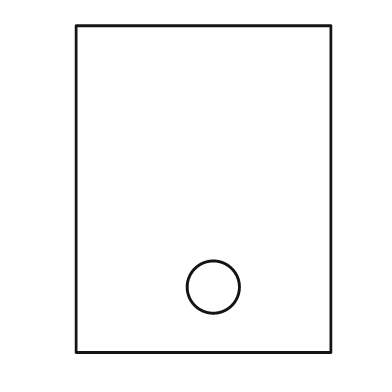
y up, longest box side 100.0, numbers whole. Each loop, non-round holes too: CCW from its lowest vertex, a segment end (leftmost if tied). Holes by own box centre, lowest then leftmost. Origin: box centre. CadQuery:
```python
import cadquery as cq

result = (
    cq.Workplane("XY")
    .moveTo(-39.0, -50.0)
    .lineTo(39.0, -50.0)
    .lineTo(39.0, 50.0)
    .lineTo(-39.0, 50.0)
    .close()
    .moveTo(3.0, -30.0)
    .circle(8.0)
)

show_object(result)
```